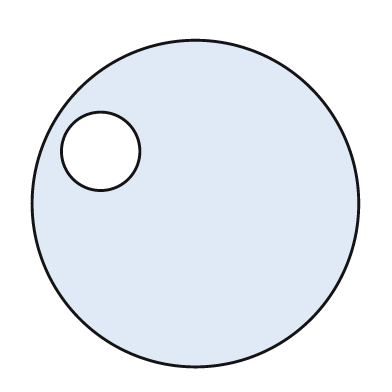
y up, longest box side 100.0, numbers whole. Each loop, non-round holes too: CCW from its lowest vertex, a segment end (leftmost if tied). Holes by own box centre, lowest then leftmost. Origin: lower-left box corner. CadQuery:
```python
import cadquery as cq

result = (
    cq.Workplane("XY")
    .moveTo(50.0, 50.0)
    .circle(50.0)
    .moveTo(21.0, 66.0)
    .circle(12.0)
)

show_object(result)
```